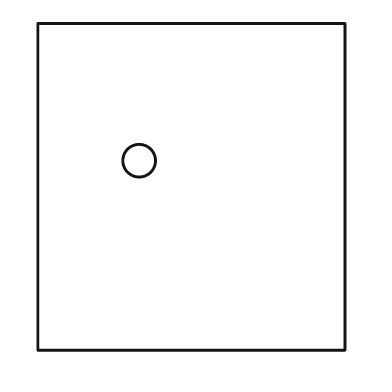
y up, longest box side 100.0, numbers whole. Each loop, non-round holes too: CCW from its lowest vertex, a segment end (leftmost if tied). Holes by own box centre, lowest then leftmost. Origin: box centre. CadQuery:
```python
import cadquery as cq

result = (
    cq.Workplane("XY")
    .moveTo(-47.0, -50.0)
    .lineTo(47.0, -50.0)
    .lineTo(47.0, 50.0)
    .lineTo(-47.0, 50.0)
    .close()
    .moveTo(-16.0, 8.0)
    .circle(5.0)
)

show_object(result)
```